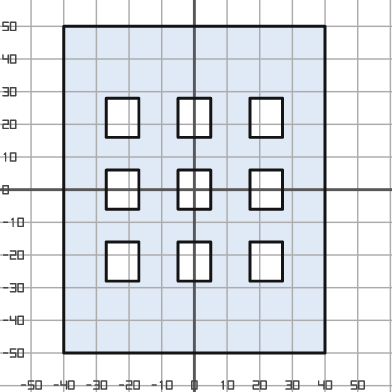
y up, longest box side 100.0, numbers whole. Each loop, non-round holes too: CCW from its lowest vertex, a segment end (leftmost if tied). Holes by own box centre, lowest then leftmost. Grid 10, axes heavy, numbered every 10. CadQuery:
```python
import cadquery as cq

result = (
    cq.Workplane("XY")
    .moveTo(-40.0, -50.0)
    .lineTo(40.0, -50.0)
    .lineTo(40.0, 50.0)
    .lineTo(-40.0, 50.0)
    .close()
    .moveTo(-27.0, -28.0)
    .lineTo(-17.0, -28.0)
    .lineTo(-17.0, -16.0)
    .lineTo(-27.0, -16.0)
    .close()
    .moveTo(-5.0, -28.0)
    .lineTo(5.0, -28.0)
    .lineTo(5.0, -16.0)
    .lineTo(-5.0, -16.0)
    .close()
    .moveTo(17.0, -28.0)
    .lineTo(27.0, -28.0)
    .lineTo(27.0, -16.0)
    .lineTo(17.0, -16.0)
    .close()
    .moveTo(-27.0, -6.0)
    .lineTo(-17.0, -6.0)
    .lineTo(-17.0, 6.0)
    .lineTo(-27.0, 6.0)
    .close()
    .moveTo(-5.0, -6.0)
    .lineTo(5.0, -6.0)
    .lineTo(5.0, 6.0)
    .lineTo(-5.0, 6.0)
    .close()
    .moveTo(17.0, -6.0)
    .lineTo(27.0, -6.0)
    .lineTo(27.0, 6.0)
    .lineTo(17.0, 6.0)
    .close()
    .moveTo(-27.0, 16.0)
    .lineTo(-17.0, 16.0)
    .lineTo(-17.0, 28.0)
    .lineTo(-27.0, 28.0)
    .close()
    .moveTo(-5.0, 16.0)
    .lineTo(5.0, 16.0)
    .lineTo(5.0, 28.0)
    .lineTo(-5.0, 28.0)
    .close()
    .moveTo(17.0, 16.0)
    .lineTo(27.0, 16.0)
    .lineTo(27.0, 28.0)
    .lineTo(17.0, 28.0)
    .close()
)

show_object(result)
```